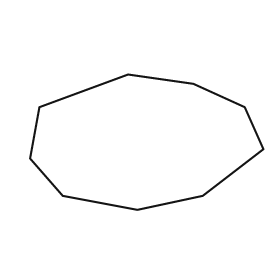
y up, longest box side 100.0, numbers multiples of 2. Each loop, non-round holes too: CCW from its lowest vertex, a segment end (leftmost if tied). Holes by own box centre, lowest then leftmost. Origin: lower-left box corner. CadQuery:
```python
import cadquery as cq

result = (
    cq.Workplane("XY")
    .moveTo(46.0, 0.0)
    .lineTo(74.0, 6.0)
    .lineTo(100.0, 26.0)
    .lineTo(92.0, 44.0)
    .lineTo(70.0, 54.0)
    .lineTo(42.0, 58.0)
    .lineTo(4.0, 44.0)
    .lineTo(0.0, 22.0)
    .lineTo(14.0, 6.0)
    .close()
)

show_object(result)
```